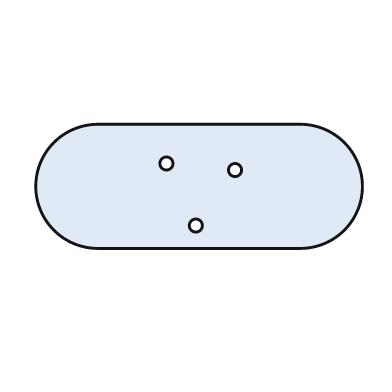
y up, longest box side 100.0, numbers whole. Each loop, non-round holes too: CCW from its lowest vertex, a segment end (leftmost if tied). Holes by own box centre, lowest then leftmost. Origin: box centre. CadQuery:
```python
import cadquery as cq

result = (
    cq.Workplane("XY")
    .moveTo(-31.0, -19.0)
    .lineTo(31.0, -19.0)
    .threePointArc((50.0, 0.0), (31.0, 19.0))
    .lineTo(-31.0, 19.0)
    .threePointArc((-50.0, 0.0), (-31.0, -19.0))
    .close()
    .moveTo(-1.0, -12.0)
    .circle(2.0)
    .moveTo(11.0, 5.0)
    .circle(2.0)
    .moveTo(-10.0, 7.0)
    .circle(2.0)
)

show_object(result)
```